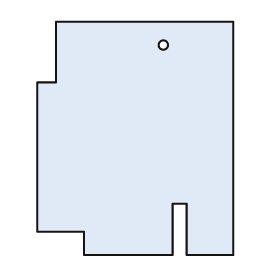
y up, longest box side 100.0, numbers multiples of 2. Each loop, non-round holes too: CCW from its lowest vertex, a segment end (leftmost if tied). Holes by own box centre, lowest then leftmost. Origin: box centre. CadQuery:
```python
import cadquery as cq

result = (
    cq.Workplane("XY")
    .moveTo(-22.0, -50.0)
    .lineTo(16.0, -50.0)
    .lineTo(16.0, -28.0)
    .lineTo(22.0, -28.0)
    .lineTo(22.0, -50.0)
    .lineTo(42.0, -50.0)
    .lineTo(42.0, 50.0)
    .lineTo(-34.0, 50.0)
    .lineTo(-34.0, 24.0)
    .lineTo(-42.0, 24.0)
    .lineTo(-42.0, -40.0)
    .lineTo(-22.0, -40.0)
    .close()
    .moveTo(12.0, 40.0)
    .circle(2.0)
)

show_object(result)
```